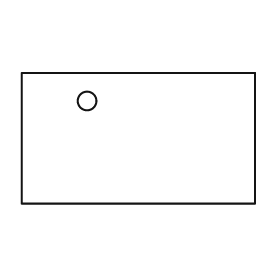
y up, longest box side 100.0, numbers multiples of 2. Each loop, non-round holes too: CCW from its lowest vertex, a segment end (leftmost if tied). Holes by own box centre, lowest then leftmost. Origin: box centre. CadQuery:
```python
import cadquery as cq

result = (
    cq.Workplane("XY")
    .moveTo(-50.0, -28.0)
    .lineTo(50.0, -28.0)
    .lineTo(50.0, 28.0)
    .lineTo(-50.0, 28.0)
    .close()
    .moveTo(-22.0, 16.0)
    .circle(4.0)
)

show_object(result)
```